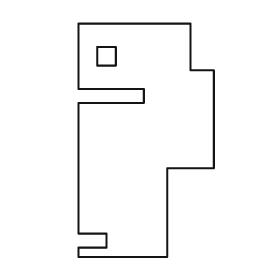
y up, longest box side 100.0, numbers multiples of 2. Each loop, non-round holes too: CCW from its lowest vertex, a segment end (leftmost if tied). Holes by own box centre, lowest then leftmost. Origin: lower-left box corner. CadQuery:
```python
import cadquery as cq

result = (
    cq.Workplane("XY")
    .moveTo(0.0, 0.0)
    .lineTo(38.0, 0.0)
    .lineTo(38.0, 38.0)
    .lineTo(58.0, 38.0)
    .lineTo(58.0, 80.0)
    .lineTo(48.0, 80.0)
    .lineTo(48.0, 100.0)
    .lineTo(0.0, 100.0)
    .lineTo(0.0, 72.0)
    .lineTo(28.0, 72.0)
    .lineTo(28.0, 66.0)
    .lineTo(0.0, 66.0)
    .lineTo(0.0, 10.0)
    .lineTo(12.0, 10.0)
    .lineTo(12.0, 4.0)
    .lineTo(0.0, 4.0)
    .close()
    .moveTo(8.0, 82.0)
    .lineTo(16.0, 82.0)
    .lineTo(16.0, 90.0)
    .lineTo(8.0, 90.0)
    .close()
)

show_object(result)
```